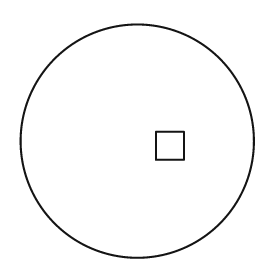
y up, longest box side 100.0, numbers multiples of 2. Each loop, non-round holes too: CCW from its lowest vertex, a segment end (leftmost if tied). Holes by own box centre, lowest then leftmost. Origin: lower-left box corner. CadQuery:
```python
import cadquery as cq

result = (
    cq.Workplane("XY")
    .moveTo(50.0, 50.0)
    .circle(50.0)
    .moveTo(58.0, 42.0)
    .lineTo(70.0, 42.0)
    .lineTo(70.0, 54.0)
    .lineTo(58.0, 54.0)
    .close()
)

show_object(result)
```